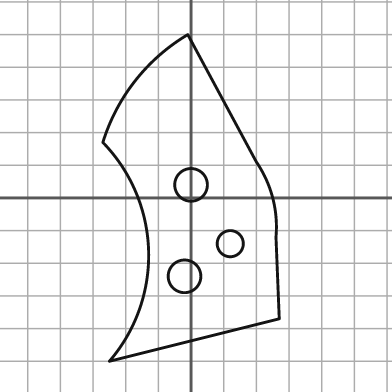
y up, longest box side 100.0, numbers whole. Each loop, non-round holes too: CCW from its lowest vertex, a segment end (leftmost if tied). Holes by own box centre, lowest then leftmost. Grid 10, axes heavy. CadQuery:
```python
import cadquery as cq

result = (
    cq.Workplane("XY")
    .moveTo(-25.0, -50.0)
    .lineTo(27.0, -37.0)
    .lineTo(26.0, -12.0)
    .threePointArc((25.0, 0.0), (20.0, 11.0))
    .lineTo(-1.0, 50.0)
    .threePointArc((-17.0, 36.0), (-27.0, 17.0))
    .threePointArc((-13.0, -16.0), (-25.0, -50.0))
    .close()
    .moveTo(-2.0, -24.0)
    .circle(5.0)
    .moveTo(12.0, -14.0)
    .circle(4.0)
    .moveTo(0.0, 4.0)
    .circle(5.0)
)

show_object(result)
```